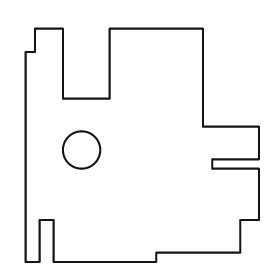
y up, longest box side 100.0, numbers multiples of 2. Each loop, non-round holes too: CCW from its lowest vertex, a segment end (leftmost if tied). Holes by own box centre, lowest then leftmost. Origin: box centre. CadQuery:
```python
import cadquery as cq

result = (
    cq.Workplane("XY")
    .moveTo(-50.0, -50.0)
    .lineTo(-44.0, -50.0)
    .lineTo(-44.0, -32.0)
    .lineTo(-38.0, -32.0)
    .lineTo(-38.0, -50.0)
    .lineTo(6.0, -50.0)
    .lineTo(6.0, -46.0)
    .lineTo(42.0, -46.0)
    .lineTo(42.0, -32.0)
    .lineTo(50.0, -32.0)
    .lineTo(50.0, -10.0)
    .lineTo(30.0, -10.0)
    .lineTo(30.0, -6.0)
    .lineTo(50.0, -6.0)
    .lineTo(50.0, 8.0)
    .lineTo(26.0, 8.0)
    .lineTo(26.0, 50.0)
    .lineTo(-14.0, 50.0)
    .lineTo(-14.0, 20.0)
    .lineTo(-34.0, 20.0)
    .lineTo(-34.0, 50.0)
    .lineTo(-46.0, 50.0)
    .lineTo(-46.0, 40.0)
    .lineTo(-50.0, 40.0)
    .close()
    .moveTo(-26.0, -2.0)
    .circle(8.0)
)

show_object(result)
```